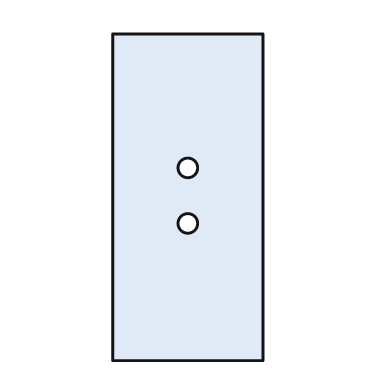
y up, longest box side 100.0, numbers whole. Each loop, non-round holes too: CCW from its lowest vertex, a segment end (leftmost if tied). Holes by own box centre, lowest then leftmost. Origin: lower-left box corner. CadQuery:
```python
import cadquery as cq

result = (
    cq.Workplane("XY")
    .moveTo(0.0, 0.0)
    .lineTo(46.0, 0.0)
    .lineTo(46.0, 100.0)
    .lineTo(0.0, 100.0)
    .close()
    .moveTo(23.0, 42.0)
    .circle(3.0)
    .moveTo(23.0, 59.0)
    .circle(3.0)
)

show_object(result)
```